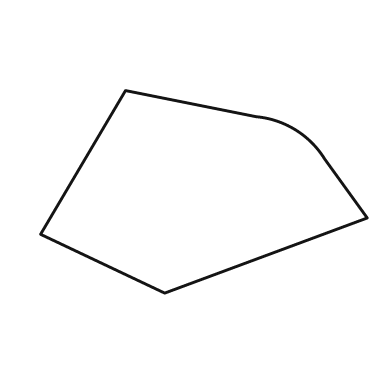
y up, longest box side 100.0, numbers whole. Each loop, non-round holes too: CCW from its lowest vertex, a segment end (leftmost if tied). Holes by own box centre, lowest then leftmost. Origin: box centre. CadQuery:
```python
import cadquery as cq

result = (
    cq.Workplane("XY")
    .moveTo(-12.0, -31.0)
    .lineTo(50.0, -8.0)
    .lineTo(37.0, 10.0)
    .threePointArc((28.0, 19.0), (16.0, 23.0))
    .lineTo(-24.0, 31.0)
    .lineTo(-50.0, -13.0)
    .close()
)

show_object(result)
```